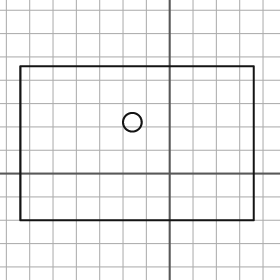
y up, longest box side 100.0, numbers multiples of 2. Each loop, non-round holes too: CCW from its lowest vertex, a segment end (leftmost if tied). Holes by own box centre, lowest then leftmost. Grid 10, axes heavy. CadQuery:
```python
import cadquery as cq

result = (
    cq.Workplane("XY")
    .moveTo(-64.0, -20.0)
    .lineTo(36.0, -20.0)
    .lineTo(36.0, 46.0)
    .lineTo(-64.0, 46.0)
    .close()
    .moveTo(-16.0, 22.0)
    .circle(4.0)
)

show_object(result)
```